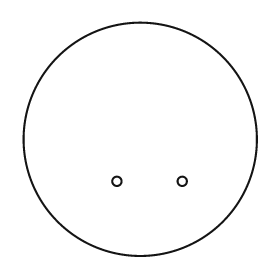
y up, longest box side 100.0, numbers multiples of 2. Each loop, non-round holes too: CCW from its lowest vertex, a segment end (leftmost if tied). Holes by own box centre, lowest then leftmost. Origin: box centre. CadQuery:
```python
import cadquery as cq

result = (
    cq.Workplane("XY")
    .moveTo(0.0, 0.0)
    .circle(50.0)
    .moveTo(-10.0, -18.0)
    .circle(2.0)
    .moveTo(18.0, -18.0)
    .circle(2.0)
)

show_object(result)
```